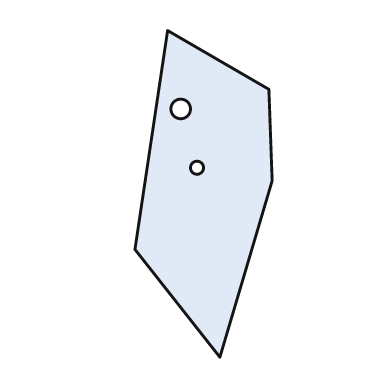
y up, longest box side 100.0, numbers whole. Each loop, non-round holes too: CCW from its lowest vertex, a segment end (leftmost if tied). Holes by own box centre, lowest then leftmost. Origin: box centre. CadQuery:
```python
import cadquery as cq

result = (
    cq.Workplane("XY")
    .moveTo(5.0, -50.0)
    .lineTo(21.0, 4.0)
    .lineTo(20.0, 32.0)
    .lineTo(-11.0, 50.0)
    .lineTo(-21.0, -17.0)
    .close()
    .moveTo(-2.0, 8.0)
    .circle(2.0)
    .moveTo(-7.0, 26.0)
    .circle(3.0)
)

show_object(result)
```